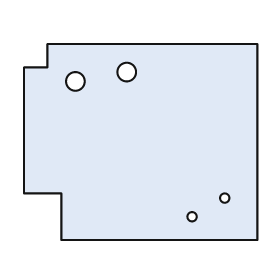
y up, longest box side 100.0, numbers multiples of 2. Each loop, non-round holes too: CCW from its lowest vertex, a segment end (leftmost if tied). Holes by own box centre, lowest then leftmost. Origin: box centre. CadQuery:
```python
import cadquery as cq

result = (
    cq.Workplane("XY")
    .moveTo(-34.0, -42.0)
    .lineTo(50.0, -42.0)
    .lineTo(50.0, 42.0)
    .lineTo(-40.0, 42.0)
    .lineTo(-40.0, 32.0)
    .lineTo(-50.0, 32.0)
    .lineTo(-50.0, -22.0)
    .lineTo(-34.0, -22.0)
    .close()
    .moveTo(22.0, -32.0)
    .circle(2.0)
    .moveTo(36.0, -24.0)
    .circle(2.0)
    .moveTo(-28.0, 26.0)
    .circle(4.0)
    .moveTo(-6.0, 30.0)
    .circle(4.0)
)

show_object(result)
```